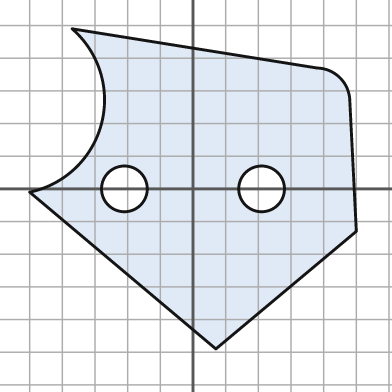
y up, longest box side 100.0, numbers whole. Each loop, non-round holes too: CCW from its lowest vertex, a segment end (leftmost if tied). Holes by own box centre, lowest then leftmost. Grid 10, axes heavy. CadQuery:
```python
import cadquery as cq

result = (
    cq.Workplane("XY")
    .moveTo(7.0, -49.0)
    .lineTo(50.0, -13.0)
    .lineTo(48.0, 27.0)
    .threePointArc((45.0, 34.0), (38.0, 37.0))
    .lineTo(-37.0, 49.0)
    .threePointArc((-28.0, 20.0), (-50.0, -1.0))
    .close()
    .moveTo(-21.0, 0.0)
    .circle(7.0)
    .moveTo(21.0, 0.0)
    .circle(7.0)
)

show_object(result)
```